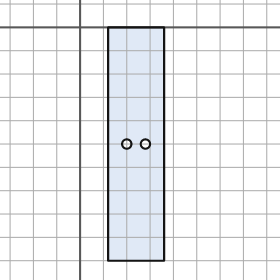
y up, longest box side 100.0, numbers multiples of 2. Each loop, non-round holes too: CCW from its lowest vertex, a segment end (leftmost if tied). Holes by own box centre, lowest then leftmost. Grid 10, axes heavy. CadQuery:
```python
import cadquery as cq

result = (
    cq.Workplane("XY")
    .moveTo(12.0, -100.0)
    .lineTo(36.0, -100.0)
    .lineTo(36.0, 0.0)
    .lineTo(12.0, 0.0)
    .close()
    .moveTo(20.0, -50.0)
    .circle(2.0)
    .moveTo(28.0, -50.0)
    .circle(2.0)
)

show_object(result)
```